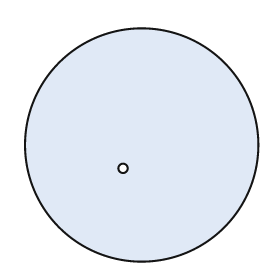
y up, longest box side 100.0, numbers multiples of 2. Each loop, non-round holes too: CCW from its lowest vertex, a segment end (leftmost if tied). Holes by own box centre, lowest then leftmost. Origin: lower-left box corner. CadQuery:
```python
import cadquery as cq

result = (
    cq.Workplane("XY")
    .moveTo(50.0, 50.0)
    .circle(50.0)
    .moveTo(42.0, 40.0)
    .circle(2.0)
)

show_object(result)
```